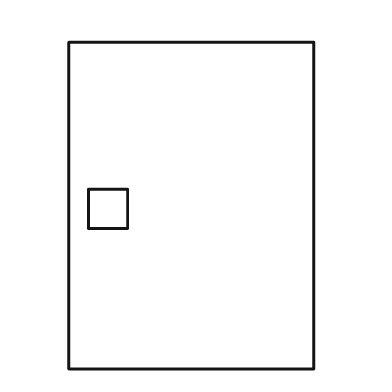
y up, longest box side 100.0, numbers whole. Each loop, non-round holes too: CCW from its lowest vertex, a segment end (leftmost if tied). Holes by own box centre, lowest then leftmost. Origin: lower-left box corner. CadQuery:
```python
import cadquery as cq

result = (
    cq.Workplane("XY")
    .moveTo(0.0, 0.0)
    .lineTo(75.0, 0.0)
    .lineTo(75.0, 100.0)
    .lineTo(0.0, 100.0)
    .close()
    .moveTo(6.0, 43.0)
    .lineTo(18.0, 43.0)
    .lineTo(18.0, 55.0)
    .lineTo(6.0, 55.0)
    .close()
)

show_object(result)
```